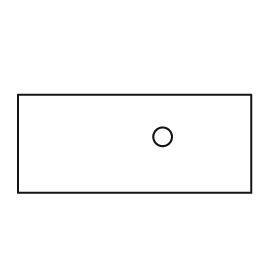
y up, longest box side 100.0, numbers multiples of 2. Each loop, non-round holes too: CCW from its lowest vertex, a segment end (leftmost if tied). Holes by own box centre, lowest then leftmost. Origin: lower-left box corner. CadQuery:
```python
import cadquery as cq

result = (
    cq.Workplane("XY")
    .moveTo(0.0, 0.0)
    .lineTo(100.0, 0.0)
    .lineTo(100.0, 42.0)
    .lineTo(0.0, 42.0)
    .close()
    .moveTo(62.0, 24.0)
    .circle(4.0)
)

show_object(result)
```